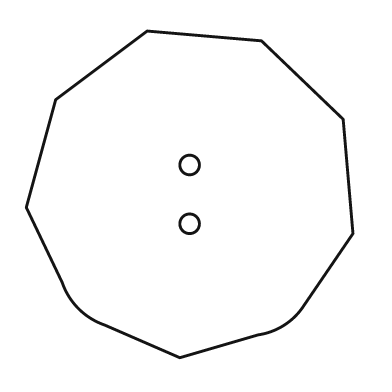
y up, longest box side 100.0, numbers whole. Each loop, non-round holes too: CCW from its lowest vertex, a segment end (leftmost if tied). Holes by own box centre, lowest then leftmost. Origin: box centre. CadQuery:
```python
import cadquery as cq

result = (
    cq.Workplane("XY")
    .moveTo(-3.0, -50.0)
    .lineTo(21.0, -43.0)
    .threePointArc((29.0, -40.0), (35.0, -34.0))
    .lineTo(50.0, -12.0)
    .lineTo(47.0, 23.0)
    .lineTo(22.0, 47.0)
    .lineTo(-13.0, 50.0)
    .lineTo(-41.0, 29.0)
    .lineTo(-50.0, -4.0)
    .lineTo(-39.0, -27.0)
    .threePointArc((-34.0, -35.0), (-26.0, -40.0))
    .close()
    .moveTo(0.0, -9.0)
    .circle(3.0)
    .moveTo(0.0, 9.0)
    .circle(3.0)
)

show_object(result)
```